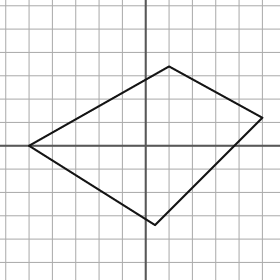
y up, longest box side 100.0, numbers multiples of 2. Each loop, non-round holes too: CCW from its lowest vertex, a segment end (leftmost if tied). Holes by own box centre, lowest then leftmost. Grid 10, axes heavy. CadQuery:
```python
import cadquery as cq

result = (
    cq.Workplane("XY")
    .moveTo(4.0, -34.0)
    .lineTo(50.0, 12.0)
    .lineTo(10.0, 34.0)
    .lineTo(-50.0, 0.0)
    .close()
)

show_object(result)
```